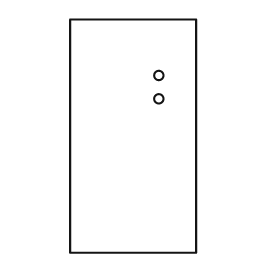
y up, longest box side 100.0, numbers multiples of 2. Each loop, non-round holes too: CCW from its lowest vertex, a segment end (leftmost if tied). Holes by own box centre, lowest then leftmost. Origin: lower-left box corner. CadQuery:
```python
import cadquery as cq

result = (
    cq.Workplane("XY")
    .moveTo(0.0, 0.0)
    .lineTo(54.0, 0.0)
    .lineTo(54.0, 100.0)
    .lineTo(0.0, 100.0)
    .close()
    .moveTo(38.0, 66.0)
    .circle(2.0)
    .moveTo(38.0, 76.0)
    .circle(2.0)
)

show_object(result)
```